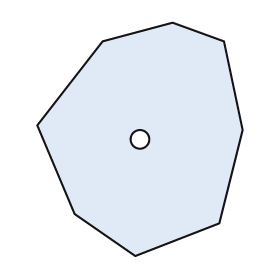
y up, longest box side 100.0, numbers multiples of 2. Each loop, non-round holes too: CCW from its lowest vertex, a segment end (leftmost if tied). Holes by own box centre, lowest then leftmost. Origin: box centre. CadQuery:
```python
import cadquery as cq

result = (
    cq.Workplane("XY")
    .moveTo(-2.0, -50.0)
    .lineTo(34.0, -36.0)
    .lineTo(44.0, 4.0)
    .lineTo(36.0, 42.0)
    .lineTo(14.0, 50.0)
    .lineTo(-16.0, 42.0)
    .lineTo(-44.0, 6.0)
    .lineTo(-28.0, -32.0)
    .close()
    .moveTo(0.0, 0.0)
    .circle(4.0)
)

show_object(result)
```